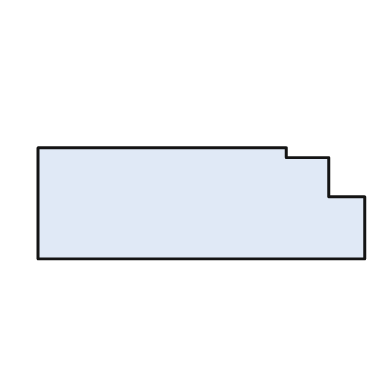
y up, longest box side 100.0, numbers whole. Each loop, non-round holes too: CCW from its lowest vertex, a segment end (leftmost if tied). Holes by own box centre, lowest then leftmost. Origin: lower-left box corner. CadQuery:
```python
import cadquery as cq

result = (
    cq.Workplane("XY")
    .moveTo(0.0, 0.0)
    .lineTo(100.0, 0.0)
    .lineTo(100.0, 19.0)
    .lineTo(89.0, 19.0)
    .lineTo(89.0, 31.0)
    .lineTo(76.0, 31.0)
    .lineTo(76.0, 34.0)
    .lineTo(0.0, 34.0)
    .close()
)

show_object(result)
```